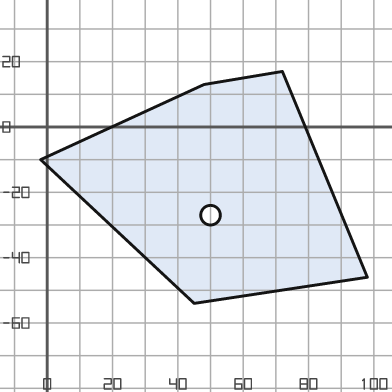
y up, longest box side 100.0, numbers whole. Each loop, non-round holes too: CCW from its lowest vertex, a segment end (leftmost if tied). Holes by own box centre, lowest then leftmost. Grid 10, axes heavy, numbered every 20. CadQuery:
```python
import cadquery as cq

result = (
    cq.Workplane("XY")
    .moveTo(45.0, -54.0)
    .lineTo(98.0, -46.0)
    .lineTo(72.0, 17.0)
    .lineTo(48.0, 13.0)
    .lineTo(-2.0, -10.0)
    .close()
    .moveTo(50.0, -27.0)
    .circle(3.0)
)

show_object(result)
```